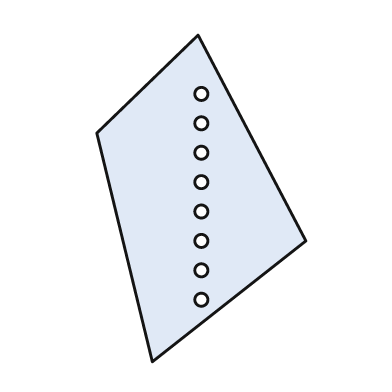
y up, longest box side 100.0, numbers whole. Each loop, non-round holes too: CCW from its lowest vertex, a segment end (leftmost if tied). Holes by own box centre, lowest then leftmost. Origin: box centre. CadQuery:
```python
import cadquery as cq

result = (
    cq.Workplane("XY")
    .moveTo(-15.0, -50.0)
    .lineTo(32.0, -13.0)
    .lineTo(-1.0, 50.0)
    .lineTo(-32.0, 20.0)
    .close()
    .moveTo(0.0, -31.0)
    .circle(2.0)
    .moveTo(0.0, -22.0)
    .circle(2.0)
    .moveTo(0.0, -13.0)
    .circle(2.0)
    .moveTo(0.0, -4.0)
    .circle(2.0)
    .moveTo(0.0, 5.0)
    .circle(2.0)
    .moveTo(0.0, 14.0)
    .circle(2.0)
    .moveTo(0.0, 23.0)
    .circle(2.0)
    .moveTo(0.0, 32.0)
    .circle(2.0)
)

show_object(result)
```